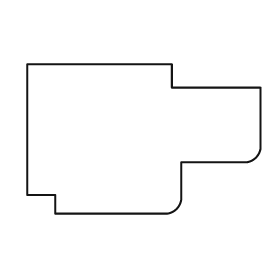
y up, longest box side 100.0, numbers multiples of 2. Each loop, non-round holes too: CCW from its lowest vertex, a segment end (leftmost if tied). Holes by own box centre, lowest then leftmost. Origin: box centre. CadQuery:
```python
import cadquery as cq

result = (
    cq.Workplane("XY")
    .moveTo(-38.0, -32.0)
    .lineTo(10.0, -32.0)
    .threePointArc((14.0, -30.0), (16.0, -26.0))
    .lineTo(16.0, -10.0)
    .lineTo(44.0, -10.0)
    .threePointArc((48.0, -8.0), (50.0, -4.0))
    .lineTo(50.0, 22.0)
    .lineTo(12.0, 22.0)
    .lineTo(12.0, 32.0)
    .lineTo(-50.0, 32.0)
    .lineTo(-50.0, -24.0)
    .lineTo(-38.0, -24.0)
    .close()
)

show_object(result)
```